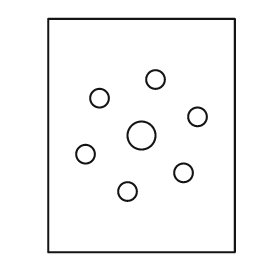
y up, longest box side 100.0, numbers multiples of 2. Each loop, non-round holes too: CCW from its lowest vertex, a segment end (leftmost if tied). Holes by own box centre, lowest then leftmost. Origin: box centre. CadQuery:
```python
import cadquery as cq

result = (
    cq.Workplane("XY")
    .moveTo(-40.0, -50.0)
    .lineTo(40.0, -50.0)
    .lineTo(40.0, 50.0)
    .lineTo(-40.0, 50.0)
    .close()
    .moveTo(-6.0, -24.0)
    .circle(4.0)
    .moveTo(18.0, -16.0)
    .circle(4.0)
    .moveTo(-24.0, -8.0)
    .circle(4.0)
    .moveTo(0.0, 0.0)
    .circle(6.0)
    .moveTo(24.0, 8.0)
    .circle(4.0)
    .moveTo(-18.0, 16.0)
    .circle(4.0)
    .moveTo(6.0, 24.0)
    .circle(4.0)
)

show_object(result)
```